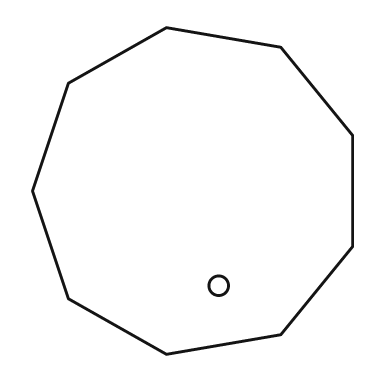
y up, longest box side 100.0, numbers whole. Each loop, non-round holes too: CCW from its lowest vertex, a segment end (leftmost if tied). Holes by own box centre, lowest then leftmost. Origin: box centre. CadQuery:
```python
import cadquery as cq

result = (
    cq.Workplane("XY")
    .moveTo(-8.0, -50.0)
    .lineTo(27.0, -44.0)
    .lineTo(49.0, -17.0)
    .lineTo(49.0, 17.0)
    .lineTo(27.0, 44.0)
    .lineTo(-8.0, 50.0)
    .lineTo(-38.0, 33.0)
    .lineTo(-49.0, 0.0)
    .lineTo(-38.0, -33.0)
    .close()
    .moveTo(8.0, -29.0)
    .circle(3.0)
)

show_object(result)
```